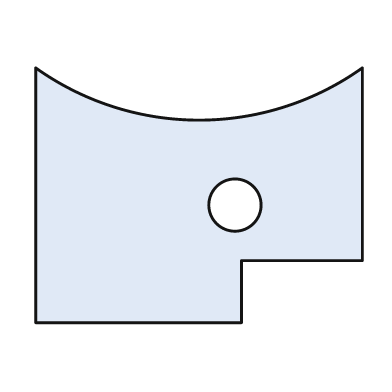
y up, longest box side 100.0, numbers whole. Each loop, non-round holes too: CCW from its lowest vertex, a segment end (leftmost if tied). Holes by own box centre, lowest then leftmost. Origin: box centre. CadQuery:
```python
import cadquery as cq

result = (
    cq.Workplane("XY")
    .moveTo(-50.0, -39.0)
    .lineTo(13.0, -39.0)
    .lineTo(13.0, -20.0)
    .lineTo(50.0, -20.0)
    .lineTo(50.0, 39.0)
    .threePointArc((0.0, 23.0), (-50.0, 39.0))
    .close()
    .moveTo(11.0, -3.0)
    .circle(8.0)
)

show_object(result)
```